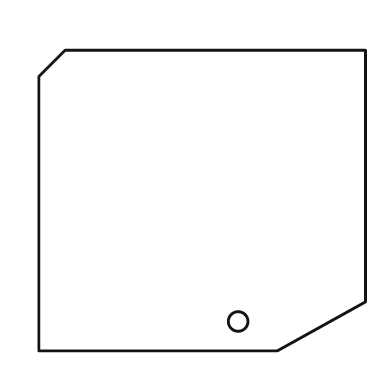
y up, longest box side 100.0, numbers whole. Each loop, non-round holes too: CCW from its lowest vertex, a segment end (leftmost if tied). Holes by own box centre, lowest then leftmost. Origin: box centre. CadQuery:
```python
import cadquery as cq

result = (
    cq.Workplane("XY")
    .moveTo(-50.0, -46.0)
    .lineTo(23.0, -46.0)
    .lineTo(50.0, -31.0)
    .lineTo(50.0, 46.0)
    .lineTo(-42.0, 46.0)
    .lineTo(-50.0, 38.0)
    .close()
    .moveTo(11.0, -37.0)
    .circle(3.0)
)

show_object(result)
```